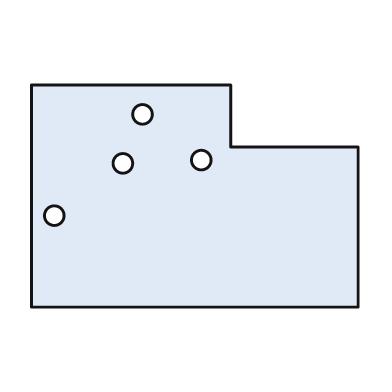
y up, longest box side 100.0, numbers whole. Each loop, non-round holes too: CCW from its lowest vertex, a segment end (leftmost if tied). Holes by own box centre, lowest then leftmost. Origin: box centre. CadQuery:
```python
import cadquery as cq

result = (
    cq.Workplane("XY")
    .moveTo(-50.0, -34.0)
    .lineTo(50.0, -34.0)
    .lineTo(50.0, 15.0)
    .lineTo(11.0, 15.0)
    .lineTo(11.0, 34.0)
    .lineTo(-50.0, 34.0)
    .close()
    .moveTo(-43.0, -6.0)
    .circle(3.0)
    .moveTo(-22.0, 10.0)
    .circle(3.0)
    .moveTo(2.0, 11.0)
    .circle(3.0)
    .moveTo(-16.0, 25.0)
    .circle(3.0)
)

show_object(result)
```